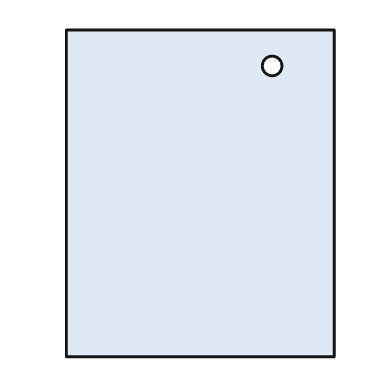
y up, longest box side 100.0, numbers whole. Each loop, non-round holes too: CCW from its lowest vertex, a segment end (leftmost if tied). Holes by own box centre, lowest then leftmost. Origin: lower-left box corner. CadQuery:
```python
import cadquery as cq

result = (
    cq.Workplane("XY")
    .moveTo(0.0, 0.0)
    .lineTo(82.0, 0.0)
    .lineTo(82.0, 100.0)
    .lineTo(0.0, 100.0)
    .close()
    .moveTo(63.0, 89.0)
    .circle(3.0)
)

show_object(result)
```